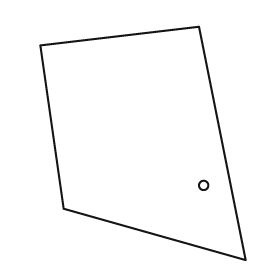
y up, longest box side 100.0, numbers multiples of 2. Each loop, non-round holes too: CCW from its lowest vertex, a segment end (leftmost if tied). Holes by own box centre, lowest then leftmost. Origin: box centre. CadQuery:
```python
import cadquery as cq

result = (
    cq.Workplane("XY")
    .moveTo(44.0, -50.0)
    .lineTo(24.0, 50.0)
    .lineTo(-44.0, 42.0)
    .lineTo(-34.0, -28.0)
    .close()
    .moveTo(26.0, -18.0)
    .circle(2.0)
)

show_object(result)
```